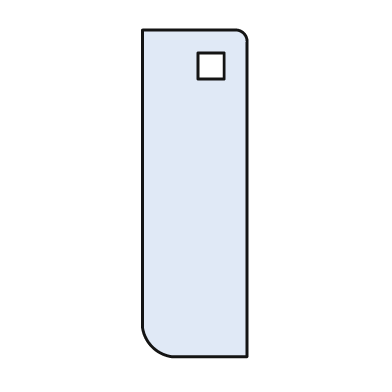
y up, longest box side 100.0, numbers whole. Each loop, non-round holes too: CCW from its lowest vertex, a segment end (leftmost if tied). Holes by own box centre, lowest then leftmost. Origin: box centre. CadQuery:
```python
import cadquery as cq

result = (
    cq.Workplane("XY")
    .moveTo(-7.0, -50.0)
    .lineTo(16.0, -50.0)
    .lineTo(16.0, 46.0)
    .threePointArc((15.0, 49.0), (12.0, 50.0))
    .lineTo(-16.0, 50.0)
    .lineTo(-16.0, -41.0)
    .threePointArc((-13.0, -47.0), (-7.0, -50.0))
    .close()
    .moveTo(1.0, 35.0)
    .lineTo(9.0, 35.0)
    .lineTo(9.0, 43.0)
    .lineTo(1.0, 43.0)
    .close()
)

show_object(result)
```